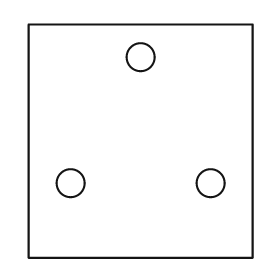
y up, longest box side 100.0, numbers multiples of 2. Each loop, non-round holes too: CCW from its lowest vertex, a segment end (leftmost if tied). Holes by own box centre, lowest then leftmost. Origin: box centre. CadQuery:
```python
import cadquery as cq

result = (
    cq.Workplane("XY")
    .moveTo(-48.0, -50.0)
    .lineTo(48.0, -50.0)
    .lineTo(48.0, 50.0)
    .lineTo(-48.0, 50.0)
    .close()
    .moveTo(-30.0, -18.0)
    .circle(6.0)
    .moveTo(30.0, -18.0)
    .circle(6.0)
    .moveTo(0.0, 36.0)
    .circle(6.0)
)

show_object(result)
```